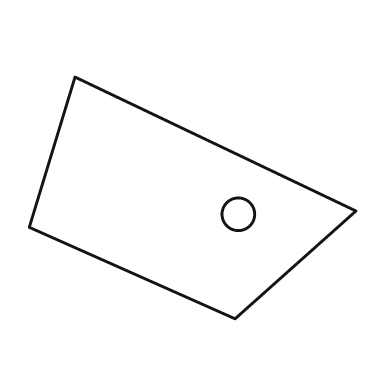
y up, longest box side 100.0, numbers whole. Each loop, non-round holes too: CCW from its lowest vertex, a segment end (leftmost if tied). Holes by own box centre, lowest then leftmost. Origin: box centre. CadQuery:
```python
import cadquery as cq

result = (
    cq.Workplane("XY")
    .moveTo(13.0, -37.0)
    .lineTo(50.0, -4.0)
    .lineTo(-36.0, 37.0)
    .lineTo(-50.0, -9.0)
    .close()
    .moveTo(14.0, -5.0)
    .circle(5.0)
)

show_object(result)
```